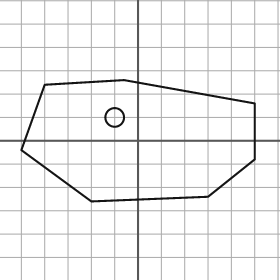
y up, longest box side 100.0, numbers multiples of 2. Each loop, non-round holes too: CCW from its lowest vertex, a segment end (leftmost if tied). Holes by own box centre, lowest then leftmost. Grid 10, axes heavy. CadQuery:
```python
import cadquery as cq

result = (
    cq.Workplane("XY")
    .moveTo(-20.0, -26.0)
    .lineTo(30.0, -24.0)
    .lineTo(50.0, -8.0)
    .lineTo(50.0, 16.0)
    .lineTo(-6.0, 26.0)
    .lineTo(-40.0, 24.0)
    .lineTo(-50.0, -4.0)
    .close()
    .moveTo(-10.0, 10.0)
    .circle(4.0)
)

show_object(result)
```